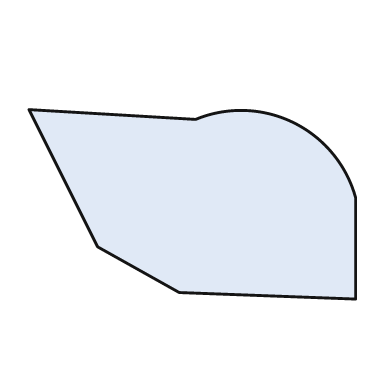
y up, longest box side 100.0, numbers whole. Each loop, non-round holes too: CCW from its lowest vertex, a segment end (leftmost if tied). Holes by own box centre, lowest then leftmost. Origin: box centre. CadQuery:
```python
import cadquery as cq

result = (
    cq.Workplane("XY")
    .moveTo(50.0, -29.0)
    .lineTo(50.0, 2.0)
    .threePointArc((31.0, 25.0), (1.0, 26.0))
    .lineTo(-50.0, 29.0)
    .lineTo(-29.0, -13.0)
    .lineTo(-4.0, -27.0)
    .close()
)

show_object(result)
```